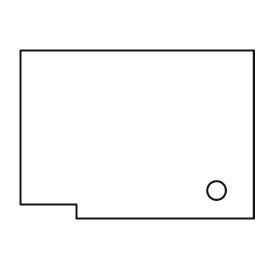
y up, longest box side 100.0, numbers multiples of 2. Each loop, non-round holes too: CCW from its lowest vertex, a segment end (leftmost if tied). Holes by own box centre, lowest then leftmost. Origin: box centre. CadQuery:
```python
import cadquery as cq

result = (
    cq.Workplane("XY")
    .moveTo(-26.0, -36.0)
    .lineTo(50.0, -36.0)
    .lineTo(50.0, 36.0)
    .lineTo(-50.0, 36.0)
    .lineTo(-50.0, -30.0)
    .lineTo(-26.0, -30.0)
    .close()
    .moveTo(34.0, -24.0)
    .circle(4.0)
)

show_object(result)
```